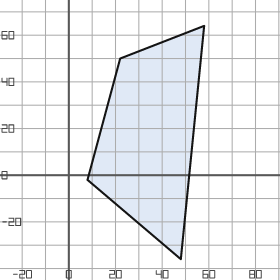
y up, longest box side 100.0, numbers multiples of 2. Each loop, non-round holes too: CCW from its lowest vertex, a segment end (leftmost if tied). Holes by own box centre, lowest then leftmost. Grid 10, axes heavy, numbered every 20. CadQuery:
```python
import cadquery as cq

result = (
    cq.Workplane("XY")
    .moveTo(48.0, -36.0)
    .lineTo(58.0, 64.0)
    .lineTo(22.0, 50.0)
    .lineTo(8.0, -2.0)
    .close()
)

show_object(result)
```